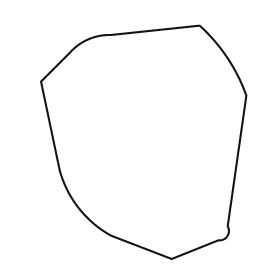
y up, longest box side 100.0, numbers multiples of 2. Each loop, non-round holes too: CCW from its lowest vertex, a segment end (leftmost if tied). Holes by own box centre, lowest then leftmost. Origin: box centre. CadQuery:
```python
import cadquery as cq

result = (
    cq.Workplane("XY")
    .moveTo(12.0, -50.0)
    .lineTo(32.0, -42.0)
    .threePointArc((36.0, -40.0), (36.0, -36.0))
    .lineTo(44.0, 20.0)
    .threePointArc((36.0, 36.0), (24.0, 50.0))
    .lineTo(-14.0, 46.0)
    .threePointArc((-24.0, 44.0), (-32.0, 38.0))
    .lineTo(-44.0, 26.0)
    .lineTo(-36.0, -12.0)
    .threePointArc((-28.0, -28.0), (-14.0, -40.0))
    .close()
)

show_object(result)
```